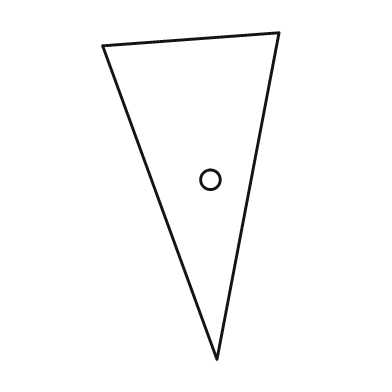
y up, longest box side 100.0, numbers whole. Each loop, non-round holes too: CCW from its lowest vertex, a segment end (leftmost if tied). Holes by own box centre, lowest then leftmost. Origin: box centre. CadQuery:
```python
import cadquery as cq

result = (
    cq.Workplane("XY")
    .moveTo(8.0, -50.0)
    .lineTo(27.0, 50.0)
    .lineTo(-27.0, 46.0)
    .close()
    .moveTo(6.0, 5.0)
    .circle(3.0)
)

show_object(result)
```